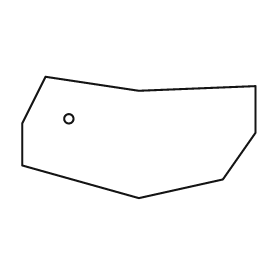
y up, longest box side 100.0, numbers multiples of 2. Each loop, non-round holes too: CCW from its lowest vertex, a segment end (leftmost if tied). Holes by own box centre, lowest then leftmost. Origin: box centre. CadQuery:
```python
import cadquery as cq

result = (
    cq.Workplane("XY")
    .moveTo(0.0, -26.0)
    .lineTo(36.0, -18.0)
    .lineTo(50.0, 2.0)
    .lineTo(50.0, 22.0)
    .lineTo(0.0, 20.0)
    .lineTo(-40.0, 26.0)
    .lineTo(-50.0, 6.0)
    .lineTo(-50.0, -12.0)
    .close()
    .moveTo(-30.0, 8.0)
    .circle(2.0)
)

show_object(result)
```